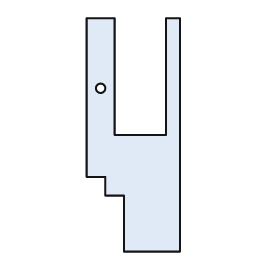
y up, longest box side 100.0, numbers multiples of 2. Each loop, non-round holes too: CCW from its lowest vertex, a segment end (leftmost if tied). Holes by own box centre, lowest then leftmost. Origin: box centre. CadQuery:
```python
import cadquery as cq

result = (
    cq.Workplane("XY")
    .moveTo(-4.0, -50.0)
    .lineTo(20.0, -50.0)
    .lineTo(20.0, 50.0)
    .lineTo(14.0, 50.0)
    .lineTo(14.0, 0.0)
    .lineTo(-8.0, 0.0)
    .lineTo(-8.0, 50.0)
    .lineTo(-20.0, 50.0)
    .lineTo(-20.0, -18.0)
    .lineTo(-12.0, -18.0)
    .lineTo(-12.0, -26.0)
    .lineTo(-4.0, -26.0)
    .close()
    .moveTo(-14.0, 20.0)
    .circle(2.0)
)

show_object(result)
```